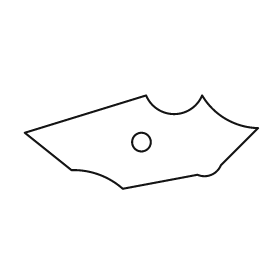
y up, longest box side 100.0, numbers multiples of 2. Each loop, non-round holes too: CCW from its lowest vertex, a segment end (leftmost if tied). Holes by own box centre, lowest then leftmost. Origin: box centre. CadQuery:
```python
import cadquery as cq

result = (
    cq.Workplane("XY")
    .moveTo(-8.0, -20.0)
    .lineTo(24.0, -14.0)
    .threePointArc((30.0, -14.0), (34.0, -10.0))
    .lineTo(50.0, 6.0)
    .threePointArc((36.0, 10.0), (26.0, 20.0))
    .threePointArc((14.0, 12.0), (2.0, 20.0))
    .lineTo(-50.0, 4.0)
    .lineTo(-30.0, -12.0)
    .threePointArc((-18.0, -14.0), (-8.0, -20.0))
    .close()
    .moveTo(0.0, 0.0)
    .circle(4.0)
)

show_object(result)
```